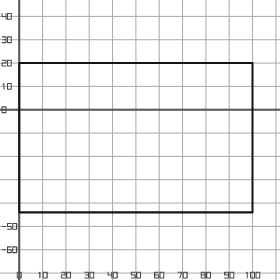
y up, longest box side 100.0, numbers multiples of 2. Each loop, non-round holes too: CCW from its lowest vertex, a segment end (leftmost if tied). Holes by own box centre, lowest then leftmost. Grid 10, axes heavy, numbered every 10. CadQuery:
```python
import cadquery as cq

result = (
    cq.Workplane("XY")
    .moveTo(0.0, -44.0)
    .lineTo(100.0, -44.0)
    .lineTo(100.0, 20.0)
    .lineTo(0.0, 20.0)
    .close()
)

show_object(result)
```